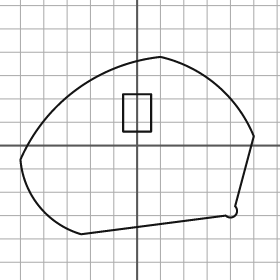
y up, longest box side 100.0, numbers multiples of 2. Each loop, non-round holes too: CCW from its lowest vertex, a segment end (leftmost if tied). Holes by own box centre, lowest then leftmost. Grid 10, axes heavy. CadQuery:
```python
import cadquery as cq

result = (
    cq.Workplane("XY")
    .moveTo(-24.0, -38.0)
    .lineTo(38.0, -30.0)
    .threePointArc((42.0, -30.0), (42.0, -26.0))
    .lineTo(50.0, 4.0)
    .threePointArc((34.0, 26.0), (10.0, 38.0))
    .threePointArc((-26.0, 24.0), (-50.0, -6.0))
    .threePointArc((-42.0, -26.0), (-24.0, -38.0))
    .close()
    .moveTo(-6.0, 6.0)
    .lineTo(6.0, 6.0)
    .lineTo(6.0, 22.0)
    .lineTo(-6.0, 22.0)
    .close()
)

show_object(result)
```